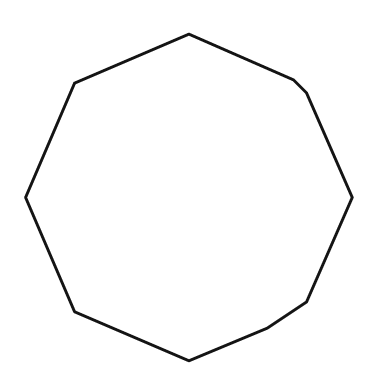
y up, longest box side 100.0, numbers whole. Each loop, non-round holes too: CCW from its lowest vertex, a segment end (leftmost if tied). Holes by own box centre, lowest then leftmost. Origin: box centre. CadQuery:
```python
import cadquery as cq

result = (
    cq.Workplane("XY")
    .moveTo(0.0, -50.0)
    .lineTo(24.0, -40.0)
    .lineTo(36.0, -32.0)
    .lineTo(50.0, 0.0)
    .lineTo(36.0, 32.0)
    .lineTo(32.0, 36.0)
    .lineTo(0.0, 50.0)
    .lineTo(-35.0, 35.0)
    .lineTo(-50.0, 0.0)
    .lineTo(-35.0, -35.0)
    .close()
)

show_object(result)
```